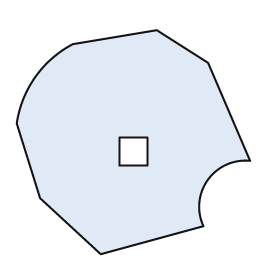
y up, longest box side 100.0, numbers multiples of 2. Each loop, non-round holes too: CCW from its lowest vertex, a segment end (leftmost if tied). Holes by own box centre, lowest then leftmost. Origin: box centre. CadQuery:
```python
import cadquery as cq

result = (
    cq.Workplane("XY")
    .moveTo(-14.0, -48.0)
    .lineTo(30.0, -36.0)
    .threePointArc((32.0, -16.0), (50.0, -8.0))
    .lineTo(32.0, 34.0)
    .lineTo(10.0, 48.0)
    .lineTo(-26.0, 42.0)
    .threePointArc((-42.0, 28.0), (-50.0, 8.0))
    .lineTo(-40.0, -24.0)
    .close()
    .moveTo(-6.0, -10.0)
    .lineTo(6.0, -10.0)
    .lineTo(6.0, 2.0)
    .lineTo(-6.0, 2.0)
    .close()
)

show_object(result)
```